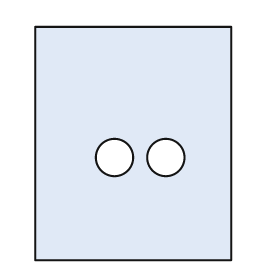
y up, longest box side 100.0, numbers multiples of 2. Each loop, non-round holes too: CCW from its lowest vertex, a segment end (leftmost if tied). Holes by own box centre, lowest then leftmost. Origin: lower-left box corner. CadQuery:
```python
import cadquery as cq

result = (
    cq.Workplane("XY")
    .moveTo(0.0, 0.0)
    .lineTo(84.0, 0.0)
    .lineTo(84.0, 100.0)
    .lineTo(0.0, 100.0)
    .close()
    .moveTo(34.0, 44.0)
    .circle(8.0)
    .moveTo(56.0, 44.0)
    .circle(8.0)
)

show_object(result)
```